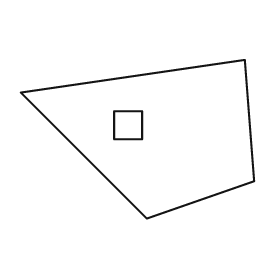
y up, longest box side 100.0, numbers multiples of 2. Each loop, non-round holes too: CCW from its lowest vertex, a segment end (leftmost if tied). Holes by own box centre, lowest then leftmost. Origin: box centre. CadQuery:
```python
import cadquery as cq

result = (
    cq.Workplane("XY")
    .moveTo(4.0, -34.0)
    .lineTo(50.0, -18.0)
    .lineTo(46.0, 34.0)
    .lineTo(-50.0, 20.0)
    .close()
    .moveTo(-10.0, 0.0)
    .lineTo(2.0, 0.0)
    .lineTo(2.0, 12.0)
    .lineTo(-10.0, 12.0)
    .close()
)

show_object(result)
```